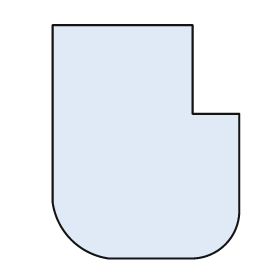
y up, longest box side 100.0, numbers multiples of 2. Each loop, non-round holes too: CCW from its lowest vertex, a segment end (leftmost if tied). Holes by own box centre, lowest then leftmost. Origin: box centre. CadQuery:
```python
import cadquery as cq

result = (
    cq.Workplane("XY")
    .moveTo(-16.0, -50.0)
    .lineTo(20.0, -50.0)
    .threePointArc((34.0, -44.0), (40.0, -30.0))
    .lineTo(40.0, 12.0)
    .lineTo(20.0, 12.0)
    .lineTo(20.0, 50.0)
    .lineTo(-40.0, 50.0)
    .lineTo(-40.0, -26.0)
    .threePointArc((-32.0, -42.0), (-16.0, -50.0))
    .close()
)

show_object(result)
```